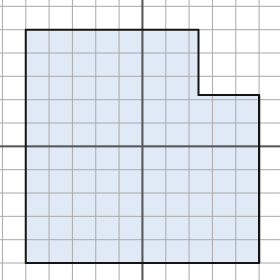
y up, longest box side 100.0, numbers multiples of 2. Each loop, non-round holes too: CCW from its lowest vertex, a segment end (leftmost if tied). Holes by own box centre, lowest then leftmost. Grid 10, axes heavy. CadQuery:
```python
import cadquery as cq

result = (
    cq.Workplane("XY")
    .moveTo(-50.0, -50.0)
    .lineTo(50.0, -50.0)
    .lineTo(50.0, 22.0)
    .lineTo(24.0, 22.0)
    .lineTo(24.0, 50.0)
    .lineTo(-50.0, 50.0)
    .close()
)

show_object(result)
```